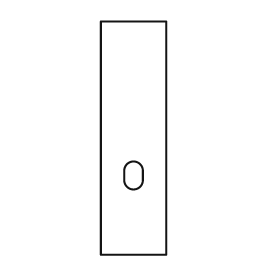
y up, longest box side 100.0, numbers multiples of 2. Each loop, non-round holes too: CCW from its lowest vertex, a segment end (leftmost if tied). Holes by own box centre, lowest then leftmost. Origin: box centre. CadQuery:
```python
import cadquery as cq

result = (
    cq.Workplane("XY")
    .moveTo(-14.0, -50.0)
    .lineTo(14.0, -50.0)
    .lineTo(14.0, 50.0)
    .lineTo(-14.0, 50.0)
    .close()
    .moveTo(-4.0, -18.0)
    .threePointArc((0.0, -22.0), (4.0, -18.0))
    .lineTo(4.0, -14.0)
    .threePointArc((0.0, -10.0), (-4.0, -14.0))
    .close()
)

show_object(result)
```